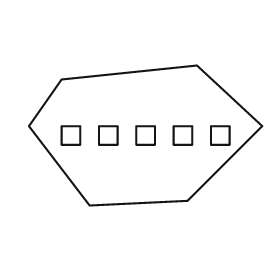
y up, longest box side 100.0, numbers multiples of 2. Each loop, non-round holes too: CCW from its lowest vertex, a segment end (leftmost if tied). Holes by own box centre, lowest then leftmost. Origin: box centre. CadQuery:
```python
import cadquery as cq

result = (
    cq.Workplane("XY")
    .moveTo(-24.0, -30.0)
    .lineTo(18.0, -28.0)
    .lineTo(50.0, 4.0)
    .lineTo(22.0, 30.0)
    .lineTo(-36.0, 24.0)
    .lineTo(-50.0, 4.0)
    .close()
    .moveTo(-36.0, -4.0)
    .lineTo(-28.0, -4.0)
    .lineTo(-28.0, 4.0)
    .lineTo(-36.0, 4.0)
    .close()
    .moveTo(-20.0, -4.0)
    .lineTo(-12.0, -4.0)
    .lineTo(-12.0, 4.0)
    .lineTo(-20.0, 4.0)
    .close()
    .moveTo(-4.0, -4.0)
    .lineTo(4.0, -4.0)
    .lineTo(4.0, 4.0)
    .lineTo(-4.0, 4.0)
    .close()
    .moveTo(12.0, -4.0)
    .lineTo(20.0, -4.0)
    .lineTo(20.0, 4.0)
    .lineTo(12.0, 4.0)
    .close()
    .moveTo(28.0, -4.0)
    .lineTo(36.0, -4.0)
    .lineTo(36.0, 4.0)
    .lineTo(28.0, 4.0)
    .close()
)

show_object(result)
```